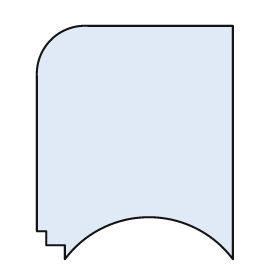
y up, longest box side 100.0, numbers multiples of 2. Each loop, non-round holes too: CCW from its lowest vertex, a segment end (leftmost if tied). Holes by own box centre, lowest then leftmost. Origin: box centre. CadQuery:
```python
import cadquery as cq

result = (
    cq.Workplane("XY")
    .moveTo(-30.0, -50.0)
    .threePointArc((6.0, -32.0), (42.0, -50.0))
    .lineTo(42.0, 50.0)
    .lineTo(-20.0, 50.0)
    .threePointArc((-36.0, 44.0), (-42.0, 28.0))
    .lineTo(-42.0, -38.0)
    .lineTo(-38.0, -38.0)
    .lineTo(-38.0, -44.0)
    .lineTo(-30.0, -44.0)
    .close()
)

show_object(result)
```